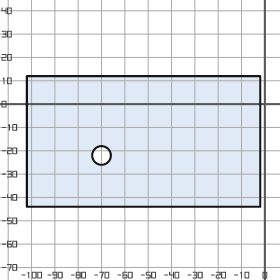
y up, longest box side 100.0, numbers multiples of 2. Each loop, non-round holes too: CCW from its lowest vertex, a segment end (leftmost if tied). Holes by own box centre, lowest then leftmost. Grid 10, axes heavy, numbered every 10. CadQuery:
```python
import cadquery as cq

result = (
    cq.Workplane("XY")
    .moveTo(-102.0, -44.0)
    .lineTo(-2.0, -44.0)
    .lineTo(-2.0, 12.0)
    .lineTo(-102.0, 12.0)
    .close()
    .moveTo(-70.0, -22.0)
    .circle(4.0)
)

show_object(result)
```